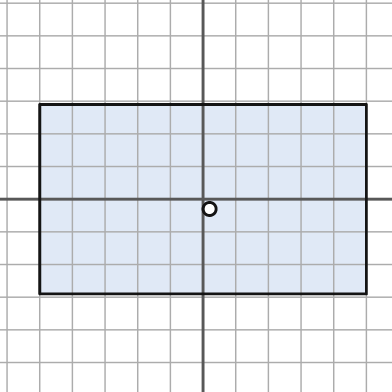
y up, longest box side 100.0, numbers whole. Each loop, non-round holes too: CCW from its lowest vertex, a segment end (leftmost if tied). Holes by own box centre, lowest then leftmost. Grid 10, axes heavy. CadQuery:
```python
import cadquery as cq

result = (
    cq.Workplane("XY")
    .moveTo(-50.0, -29.0)
    .lineTo(50.0, -29.0)
    .lineTo(50.0, 29.0)
    .lineTo(-50.0, 29.0)
    .close()
    .moveTo(2.0, -3.0)
    .circle(2.0)
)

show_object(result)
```